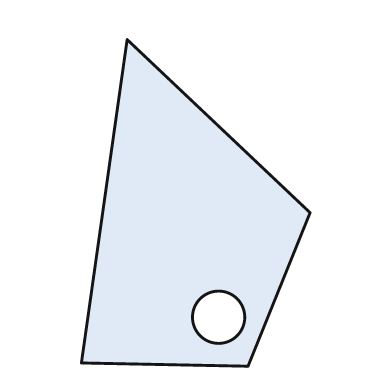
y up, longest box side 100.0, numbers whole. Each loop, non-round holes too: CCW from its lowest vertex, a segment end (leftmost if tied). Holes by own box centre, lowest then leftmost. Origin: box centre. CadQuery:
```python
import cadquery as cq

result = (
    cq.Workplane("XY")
    .moveTo(16.0, -50.0)
    .lineTo(35.0, -3.0)
    .lineTo(-21.0, 50.0)
    .lineTo(-35.0, -49.0)
    .close()
    .moveTo(7.0, -35.0)
    .circle(8.0)
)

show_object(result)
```